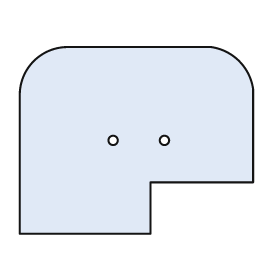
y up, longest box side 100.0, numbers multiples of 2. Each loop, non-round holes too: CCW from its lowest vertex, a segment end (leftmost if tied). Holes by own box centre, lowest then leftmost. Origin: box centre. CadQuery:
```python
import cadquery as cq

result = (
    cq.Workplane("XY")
    .moveTo(-50.0, -40.0)
    .lineTo(6.0, -40.0)
    .lineTo(6.0, -18.0)
    .lineTo(50.0, -18.0)
    .lineTo(50.0, 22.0)
    .threePointArc((44.0, 34.0), (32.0, 40.0))
    .lineTo(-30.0, 40.0)
    .threePointArc((-44.0, 34.0), (-50.0, 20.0))
    .close()
    .moveTo(-10.0, 0.0)
    .circle(2.0)
    .moveTo(12.0, 0.0)
    .circle(2.0)
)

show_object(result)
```